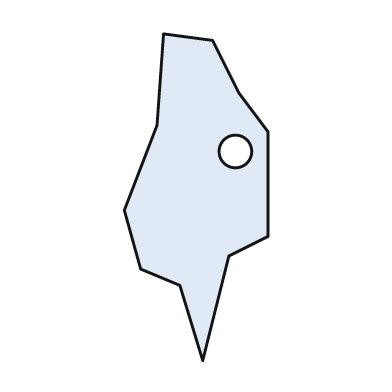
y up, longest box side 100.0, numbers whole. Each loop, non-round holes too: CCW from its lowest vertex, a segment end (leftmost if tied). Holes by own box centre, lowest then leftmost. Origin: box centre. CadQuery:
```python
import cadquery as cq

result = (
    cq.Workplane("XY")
    .moveTo(2.0, -50.0)
    .lineTo(10.0, -18.0)
    .lineTo(22.0, -12.0)
    .lineTo(22.0, 20.0)
    .lineTo(13.0, 32.0)
    .lineTo(5.0, 48.0)
    .lineTo(-10.0, 50.0)
    .lineTo(-12.0, 22.0)
    .lineTo(-22.0, -4.0)
    .lineTo(-17.0, -22.0)
    .lineTo(-5.0, -27.0)
    .close()
    .moveTo(12.0, 14.0)
    .circle(5.0)
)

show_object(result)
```